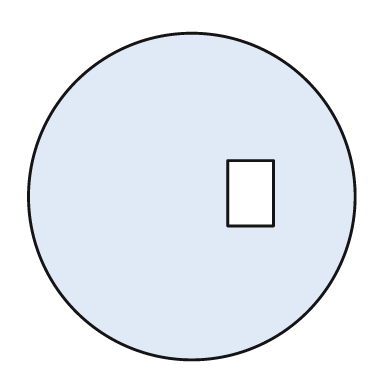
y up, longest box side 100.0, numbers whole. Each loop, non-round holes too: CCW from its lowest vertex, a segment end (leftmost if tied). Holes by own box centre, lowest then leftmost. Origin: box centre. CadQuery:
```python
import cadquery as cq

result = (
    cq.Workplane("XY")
    .moveTo(0.0, 0.0)
    .circle(50.0)
    .moveTo(11.0, -9.0)
    .lineTo(25.0, -9.0)
    .lineTo(25.0, 11.0)
    .lineTo(11.0, 11.0)
    .close()
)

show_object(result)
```